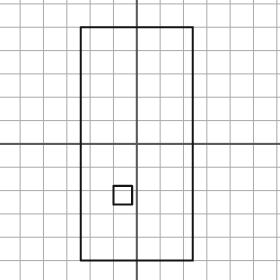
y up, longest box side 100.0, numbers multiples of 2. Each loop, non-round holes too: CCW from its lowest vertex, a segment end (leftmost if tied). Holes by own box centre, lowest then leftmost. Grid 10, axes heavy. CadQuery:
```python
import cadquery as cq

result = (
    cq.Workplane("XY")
    .moveTo(-24.0, -50.0)
    .lineTo(24.0, -50.0)
    .lineTo(24.0, 50.0)
    .lineTo(-24.0, 50.0)
    .close()
    .moveTo(-10.0, -26.0)
    .lineTo(-2.0, -26.0)
    .lineTo(-2.0, -18.0)
    .lineTo(-10.0, -18.0)
    .close()
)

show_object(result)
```